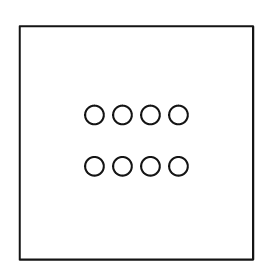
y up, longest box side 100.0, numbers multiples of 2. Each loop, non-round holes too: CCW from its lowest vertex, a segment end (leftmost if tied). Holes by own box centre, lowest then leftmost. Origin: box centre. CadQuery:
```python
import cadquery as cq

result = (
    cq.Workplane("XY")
    .moveTo(-50.0, -50.0)
    .lineTo(50.0, -50.0)
    .lineTo(50.0, 50.0)
    .lineTo(-50.0, 50.0)
    .close()
    .moveTo(-18.0, -10.0)
    .circle(4.0)
    .moveTo(-6.0, -10.0)
    .circle(4.0)
    .moveTo(6.0, -10.0)
    .circle(4.0)
    .moveTo(18.0, -10.0)
    .circle(4.0)
    .moveTo(-18.0, 12.0)
    .circle(4.0)
    .moveTo(-6.0, 12.0)
    .circle(4.0)
    .moveTo(6.0, 12.0)
    .circle(4.0)
    .moveTo(18.0, 12.0)
    .circle(4.0)
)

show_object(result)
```